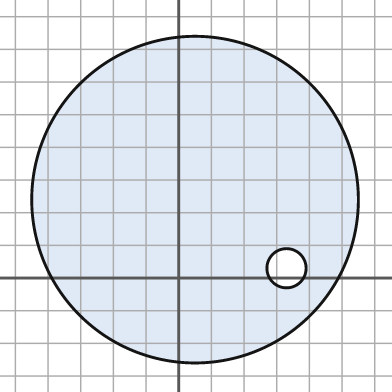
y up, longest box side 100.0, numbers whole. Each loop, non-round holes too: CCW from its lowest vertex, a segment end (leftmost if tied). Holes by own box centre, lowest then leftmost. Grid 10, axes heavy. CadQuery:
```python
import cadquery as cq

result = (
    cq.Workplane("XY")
    .moveTo(5.0, 24.0)
    .circle(50.0)
    .moveTo(33.0, 3.0)
    .circle(6.0)
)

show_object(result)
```